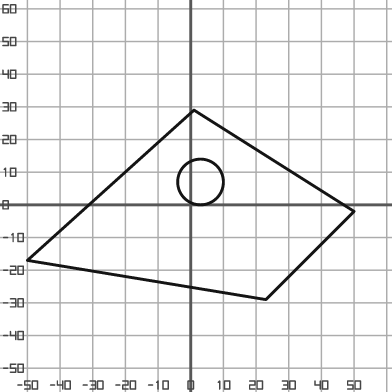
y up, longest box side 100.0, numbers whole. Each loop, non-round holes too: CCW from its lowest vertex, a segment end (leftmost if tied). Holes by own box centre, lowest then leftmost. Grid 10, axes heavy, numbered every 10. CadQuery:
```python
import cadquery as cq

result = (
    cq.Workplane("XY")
    .moveTo(23.0, -29.0)
    .lineTo(50.0, -2.0)
    .lineTo(1.0, 29.0)
    .lineTo(-50.0, -17.0)
    .close()
    .moveTo(3.0, 7.0)
    .circle(7.0)
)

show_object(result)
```